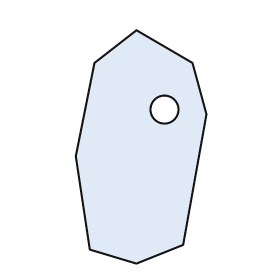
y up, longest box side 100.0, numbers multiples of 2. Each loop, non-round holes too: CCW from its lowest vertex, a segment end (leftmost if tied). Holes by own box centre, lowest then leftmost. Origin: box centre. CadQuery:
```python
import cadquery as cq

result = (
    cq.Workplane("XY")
    .moveTo(-2.0, -50.0)
    .lineTo(18.0, -42.0)
    .lineTo(28.0, 14.0)
    .lineTo(22.0, 36.0)
    .lineTo(-2.0, 50.0)
    .lineTo(-20.0, 36.0)
    .lineTo(-28.0, -4.0)
    .lineTo(-22.0, -44.0)
    .close()
    .moveTo(10.0, 16.0)
    .circle(6.0)
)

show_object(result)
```